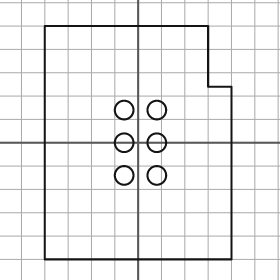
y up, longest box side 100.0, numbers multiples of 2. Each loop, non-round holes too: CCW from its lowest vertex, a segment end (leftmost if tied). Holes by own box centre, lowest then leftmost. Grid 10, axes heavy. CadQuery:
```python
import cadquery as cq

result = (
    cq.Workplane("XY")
    .moveTo(-40.0, -50.0)
    .lineTo(40.0, -50.0)
    .lineTo(40.0, 24.0)
    .lineTo(30.0, 24.0)
    .lineTo(30.0, 50.0)
    .lineTo(-40.0, 50.0)
    .close()
    .moveTo(-6.0, -14.0)
    .circle(4.0)
    .moveTo(8.0, -14.0)
    .circle(4.0)
    .moveTo(-6.0, 0.0)
    .circle(4.0)
    .moveTo(8.0, 0.0)
    .circle(4.0)
    .moveTo(-6.0, 14.0)
    .circle(4.0)
    .moveTo(8.0, 14.0)
    .circle(4.0)
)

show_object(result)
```